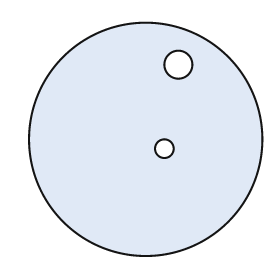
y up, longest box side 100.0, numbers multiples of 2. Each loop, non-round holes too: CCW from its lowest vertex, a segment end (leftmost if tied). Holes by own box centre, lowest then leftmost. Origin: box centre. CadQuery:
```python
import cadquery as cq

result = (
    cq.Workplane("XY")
    .moveTo(0.0, 0.0)
    .circle(50.0)
    .moveTo(8.0, -4.0)
    .circle(4.0)
    .moveTo(14.0, 32.0)
    .circle(6.0)
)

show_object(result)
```